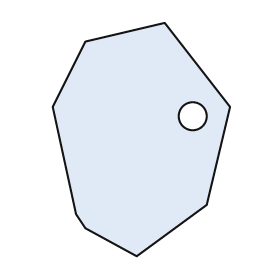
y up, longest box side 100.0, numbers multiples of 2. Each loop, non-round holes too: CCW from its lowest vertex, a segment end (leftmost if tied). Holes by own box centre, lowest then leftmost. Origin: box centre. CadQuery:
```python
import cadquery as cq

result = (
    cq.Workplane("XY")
    .moveTo(-2.0, -50.0)
    .lineTo(28.0, -28.0)
    .lineTo(38.0, 14.0)
    .lineTo(10.0, 50.0)
    .lineTo(-24.0, 42.0)
    .lineTo(-38.0, 14.0)
    .lineTo(-28.0, -32.0)
    .lineTo(-24.0, -38.0)
    .close()
    .moveTo(22.0, 10.0)
    .circle(6.0)
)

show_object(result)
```